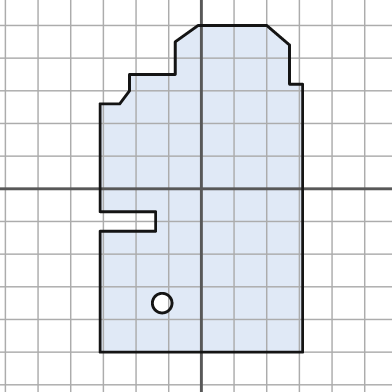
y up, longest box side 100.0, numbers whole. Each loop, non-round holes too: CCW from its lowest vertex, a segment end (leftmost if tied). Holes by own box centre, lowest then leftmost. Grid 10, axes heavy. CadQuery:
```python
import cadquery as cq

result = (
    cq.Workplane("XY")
    .moveTo(-31.0, -50.0)
    .lineTo(31.0, -50.0)
    .lineTo(31.0, 32.0)
    .lineTo(27.0, 32.0)
    .lineTo(27.0, 44.0)
    .lineTo(20.0, 50.0)
    .lineTo(-1.0, 50.0)
    .lineTo(-8.0, 45.0)
    .lineTo(-8.0, 35.0)
    .lineTo(-22.0, 35.0)
    .lineTo(-22.0, 30.0)
    .lineTo(-25.0, 26.0)
    .lineTo(-31.0, 26.0)
    .lineTo(-31.0, -7.0)
    .lineTo(-14.0, -7.0)
    .lineTo(-14.0, -13.0)
    .lineTo(-31.0, -13.0)
    .close()
    .moveTo(-12.0, -35.0)
    .circle(3.0)
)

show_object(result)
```